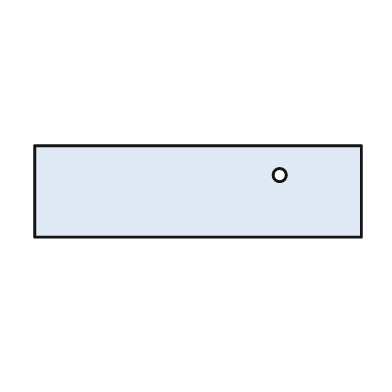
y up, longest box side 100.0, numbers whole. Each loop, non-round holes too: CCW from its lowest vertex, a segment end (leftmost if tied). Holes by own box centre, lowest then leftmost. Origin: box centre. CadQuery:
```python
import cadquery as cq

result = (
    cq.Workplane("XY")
    .moveTo(-50.0, -14.0)
    .lineTo(50.0, -14.0)
    .lineTo(50.0, 14.0)
    .lineTo(-50.0, 14.0)
    .close()
    .moveTo(25.0, 5.0)
    .circle(2.0)
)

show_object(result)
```